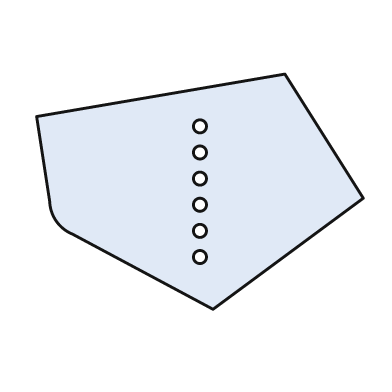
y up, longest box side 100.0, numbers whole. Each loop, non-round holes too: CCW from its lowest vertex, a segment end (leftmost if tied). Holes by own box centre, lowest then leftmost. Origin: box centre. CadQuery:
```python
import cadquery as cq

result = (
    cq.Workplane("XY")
    .moveTo(4.0, -36.0)
    .lineTo(50.0, -2.0)
    .lineTo(26.0, 36.0)
    .lineTo(-50.0, 23.0)
    .lineTo(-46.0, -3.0)
    .threePointArc((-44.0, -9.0), (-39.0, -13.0))
    .close()
    .moveTo(0.0, -20.0)
    .circle(2.0)
    .moveTo(0.0, -12.0)
    .circle(2.0)
    .moveTo(0.0, -4.0)
    .circle(2.0)
    .moveTo(0.0, 4.0)
    .circle(2.0)
    .moveTo(0.0, 12.0)
    .circle(2.0)
    .moveTo(0.0, 20.0)
    .circle(2.0)
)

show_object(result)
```